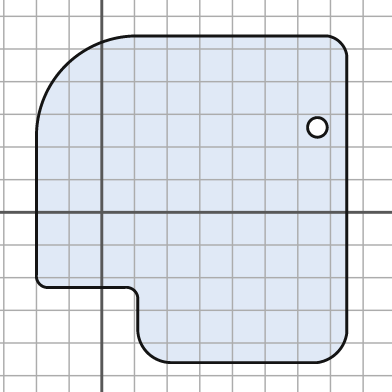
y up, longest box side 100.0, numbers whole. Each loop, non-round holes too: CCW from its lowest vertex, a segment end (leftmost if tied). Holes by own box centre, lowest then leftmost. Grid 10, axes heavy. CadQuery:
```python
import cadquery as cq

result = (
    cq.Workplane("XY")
    .moveTo(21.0, -46.0)
    .lineTo(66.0, -46.0)
    .threePointArc((72.0, -43.0), (75.0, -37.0))
    .lineTo(75.0, 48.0)
    .threePointArc((73.0, 52.0), (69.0, 54.0))
    .lineTo(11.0, 54.0)
    .threePointArc((-11.0, 45.0), (-20.0, 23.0))
    .lineTo(-20.0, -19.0)
    .threePointArc((-19.0, -22.0), (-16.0, -23.0))
    .lineTo(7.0, -23.0)
    .threePointArc((10.0, -24.0), (11.0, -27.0))
    .lineTo(11.0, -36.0)
    .threePointArc((14.0, -43.0), (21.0, -46.0))
    .close()
    .moveTo(66.0, 26.0)
    .circle(3.0)
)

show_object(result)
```